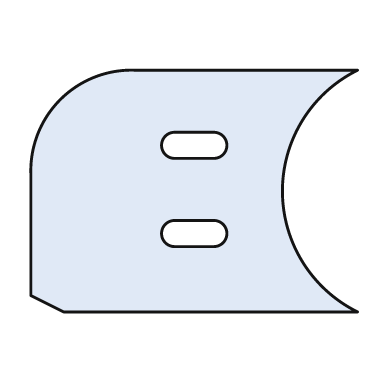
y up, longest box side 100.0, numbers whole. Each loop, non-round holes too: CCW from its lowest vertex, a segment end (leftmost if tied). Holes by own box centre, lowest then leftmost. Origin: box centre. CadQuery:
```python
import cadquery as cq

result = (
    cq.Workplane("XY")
    .moveTo(-40.0, -37.0)
    .lineTo(50.0, -37.0)
    .threePointArc((27.0, 0.0), (50.0, 37.0))
    .lineTo(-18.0, 37.0)
    .threePointArc((-41.0, 28.0), (-50.0, 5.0))
    .lineTo(-50.0, -32.0)
    .close()
    .moveTo(-6.0, -17.0)
    .lineTo(6.0, -17.0)
    .threePointArc((10.0, -13.0), (6.0, -9.0))
    .lineTo(-6.0, -9.0)
    .threePointArc((-10.0, -13.0), (-6.0, -17.0))
    .close()
    .moveTo(-6.0, 10.0)
    .lineTo(6.0, 10.0)
    .threePointArc((10.0, 14.0), (6.0, 18.0))
    .lineTo(-6.0, 18.0)
    .threePointArc((-10.0, 14.0), (-6.0, 10.0))
    .close()
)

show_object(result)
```